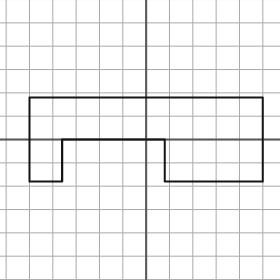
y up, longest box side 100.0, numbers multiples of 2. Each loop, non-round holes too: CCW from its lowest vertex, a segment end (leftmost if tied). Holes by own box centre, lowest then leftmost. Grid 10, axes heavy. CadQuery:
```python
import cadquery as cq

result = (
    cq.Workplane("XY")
    .moveTo(-50.0, -18.0)
    .lineTo(-36.0, -18.0)
    .lineTo(-36.0, 0.0)
    .lineTo(8.0, 0.0)
    .lineTo(8.0, -18.0)
    .lineTo(50.0, -18.0)
    .lineTo(50.0, 18.0)
    .lineTo(-50.0, 18.0)
    .close()
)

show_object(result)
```